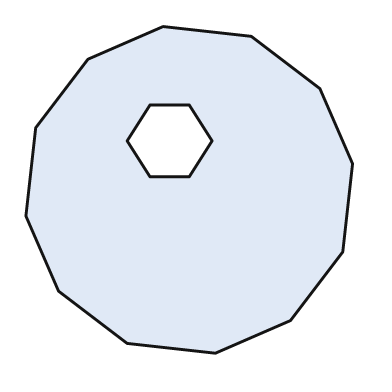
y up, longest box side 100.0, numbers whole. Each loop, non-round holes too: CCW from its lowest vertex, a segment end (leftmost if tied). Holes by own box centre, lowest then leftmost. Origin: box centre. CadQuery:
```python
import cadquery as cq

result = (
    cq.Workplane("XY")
    .moveTo(8.0, -50.0)
    .lineTo(31.0, -40.0)
    .lineTo(47.0, -19.0)
    .lineTo(50.0, 8.0)
    .lineTo(40.0, 31.0)
    .lineTo(19.0, 47.0)
    .lineTo(-8.0, 50.0)
    .lineTo(-31.0, 40.0)
    .lineTo(-47.0, 19.0)
    .lineTo(-50.0, -8.0)
    .lineTo(-40.0, -31.0)
    .lineTo(-19.0, -47.0)
    .close()
    .moveTo(-12.0, 4.0)
    .lineTo(0.0, 4.0)
    .lineTo(7.0, 15.0)
    .lineTo(0.0, 26.0)
    .lineTo(-12.0, 26.0)
    .lineTo(-19.0, 15.0)
    .close()
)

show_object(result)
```